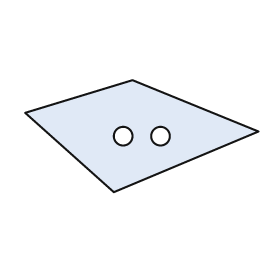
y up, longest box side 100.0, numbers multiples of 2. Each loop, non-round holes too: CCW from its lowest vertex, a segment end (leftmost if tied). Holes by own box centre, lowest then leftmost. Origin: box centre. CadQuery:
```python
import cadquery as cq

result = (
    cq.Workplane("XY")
    .moveTo(-12.0, -24.0)
    .lineTo(50.0, 2.0)
    .lineTo(-4.0, 24.0)
    .lineTo(-50.0, 10.0)
    .close()
    .moveTo(-8.0, 0.0)
    .circle(4.0)
    .moveTo(8.0, 0.0)
    .circle(4.0)
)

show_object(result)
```